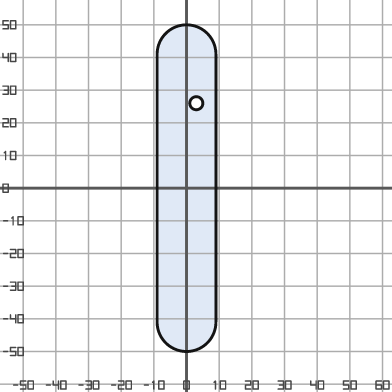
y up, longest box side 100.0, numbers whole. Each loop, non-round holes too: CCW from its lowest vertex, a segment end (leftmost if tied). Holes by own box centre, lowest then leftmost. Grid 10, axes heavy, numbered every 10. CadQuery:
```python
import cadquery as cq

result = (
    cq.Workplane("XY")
    .moveTo(-9.0, -41.0)
    .threePointArc((0.0, -50.0), (9.0, -41.0))
    .lineTo(9.0, 41.0)
    .threePointArc((0.0, 50.0), (-9.0, 41.0))
    .close()
    .moveTo(3.0, 26.0)
    .circle(2.0)
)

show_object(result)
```